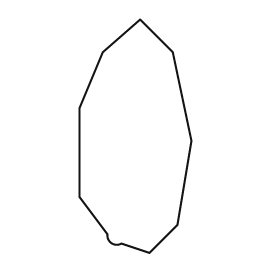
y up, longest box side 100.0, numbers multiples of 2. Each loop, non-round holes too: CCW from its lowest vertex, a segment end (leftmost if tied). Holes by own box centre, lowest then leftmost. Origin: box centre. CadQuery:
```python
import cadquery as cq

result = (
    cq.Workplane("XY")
    .moveTo(6.0, -50.0)
    .lineTo(18.0, -38.0)
    .lineTo(24.0, -2.0)
    .lineTo(16.0, 36.0)
    .lineTo(2.0, 50.0)
    .lineTo(-14.0, 36.0)
    .lineTo(-24.0, 12.0)
    .lineTo(-24.0, -26.0)
    .lineTo(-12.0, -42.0)
    .threePointArc((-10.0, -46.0), (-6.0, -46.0))
    .close()
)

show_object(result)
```